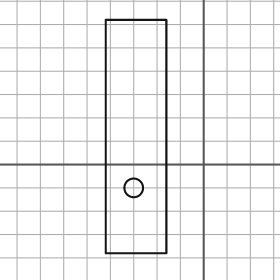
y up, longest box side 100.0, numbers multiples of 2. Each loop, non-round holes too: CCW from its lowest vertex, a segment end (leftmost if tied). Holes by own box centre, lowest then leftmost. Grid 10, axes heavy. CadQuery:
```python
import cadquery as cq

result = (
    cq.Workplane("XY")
    .moveTo(-42.0, -38.0)
    .lineTo(-16.0, -38.0)
    .lineTo(-16.0, 62.0)
    .lineTo(-42.0, 62.0)
    .close()
    .moveTo(-30.0, -10.0)
    .circle(4.0)
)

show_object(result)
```